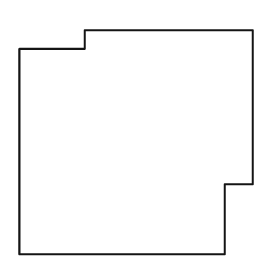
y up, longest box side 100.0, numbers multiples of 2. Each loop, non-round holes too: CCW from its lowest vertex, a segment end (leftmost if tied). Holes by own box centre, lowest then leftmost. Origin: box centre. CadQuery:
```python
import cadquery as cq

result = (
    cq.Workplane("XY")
    .moveTo(-50.0, -48.0)
    .lineTo(38.0, -48.0)
    .lineTo(38.0, -18.0)
    .lineTo(50.0, -18.0)
    .lineTo(50.0, 48.0)
    .lineTo(-22.0, 48.0)
    .lineTo(-22.0, 40.0)
    .lineTo(-50.0, 40.0)
    .close()
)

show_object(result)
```